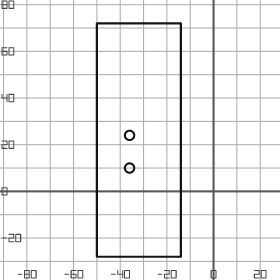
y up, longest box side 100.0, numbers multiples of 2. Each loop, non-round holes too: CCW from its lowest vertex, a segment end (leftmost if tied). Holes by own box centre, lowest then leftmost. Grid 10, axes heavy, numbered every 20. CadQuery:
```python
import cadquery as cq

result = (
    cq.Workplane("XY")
    .moveTo(-50.0, -28.0)
    .lineTo(-14.0, -28.0)
    .lineTo(-14.0, 72.0)
    .lineTo(-50.0, 72.0)
    .close()
    .moveTo(-36.0, 10.0)
    .circle(2.0)
    .moveTo(-36.0, 24.0)
    .circle(2.0)
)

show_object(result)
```